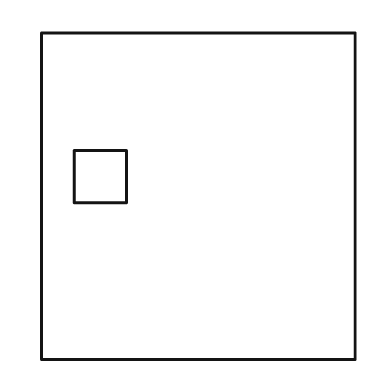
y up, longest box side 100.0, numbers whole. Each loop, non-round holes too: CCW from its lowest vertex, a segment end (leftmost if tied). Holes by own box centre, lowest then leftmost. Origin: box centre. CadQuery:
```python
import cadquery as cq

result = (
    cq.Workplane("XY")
    .moveTo(-48.0, -50.0)
    .lineTo(48.0, -50.0)
    .lineTo(48.0, 50.0)
    .lineTo(-48.0, 50.0)
    .close()
    .moveTo(-38.0, -2.0)
    .lineTo(-22.0, -2.0)
    .lineTo(-22.0, 14.0)
    .lineTo(-38.0, 14.0)
    .close()
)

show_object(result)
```